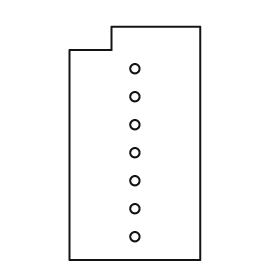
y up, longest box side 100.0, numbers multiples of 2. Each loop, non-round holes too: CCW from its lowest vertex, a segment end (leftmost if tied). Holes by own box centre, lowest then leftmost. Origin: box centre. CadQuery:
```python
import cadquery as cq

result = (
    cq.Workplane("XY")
    .moveTo(-28.0, -50.0)
    .lineTo(28.0, -50.0)
    .lineTo(28.0, 50.0)
    .lineTo(-10.0, 50.0)
    .lineTo(-10.0, 40.0)
    .lineTo(-28.0, 40.0)
    .close()
    .moveTo(0.0, -40.0)
    .circle(2.0)
    .moveTo(0.0, -28.0)
    .circle(2.0)
    .moveTo(0.0, -16.0)
    .circle(2.0)
    .moveTo(0.0, -4.0)
    .circle(2.0)
    .moveTo(0.0, 8.0)
    .circle(2.0)
    .moveTo(0.0, 20.0)
    .circle(2.0)
    .moveTo(0.0, 32.0)
    .circle(2.0)
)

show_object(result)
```